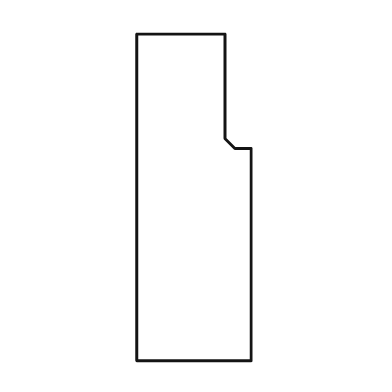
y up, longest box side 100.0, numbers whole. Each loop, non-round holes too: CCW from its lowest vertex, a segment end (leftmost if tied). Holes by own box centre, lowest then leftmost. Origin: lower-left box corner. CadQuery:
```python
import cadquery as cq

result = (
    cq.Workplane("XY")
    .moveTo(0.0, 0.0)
    .lineTo(35.0, 0.0)
    .lineTo(35.0, 65.0)
    .lineTo(30.0, 65.0)
    .lineTo(27.0, 68.0)
    .lineTo(27.0, 100.0)
    .lineTo(0.0, 100.0)
    .close()
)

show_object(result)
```